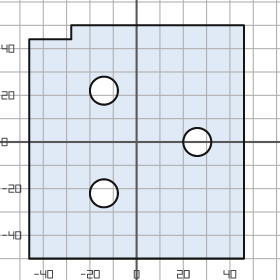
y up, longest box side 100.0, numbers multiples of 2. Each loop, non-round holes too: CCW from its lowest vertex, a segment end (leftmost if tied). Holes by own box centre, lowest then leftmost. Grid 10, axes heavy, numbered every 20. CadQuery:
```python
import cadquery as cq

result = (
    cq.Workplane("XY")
    .moveTo(-46.0, -50.0)
    .lineTo(46.0, -50.0)
    .lineTo(46.0, 50.0)
    .lineTo(-28.0, 50.0)
    .lineTo(-28.0, 44.0)
    .lineTo(-46.0, 44.0)
    .close()
    .moveTo(-14.0, -22.0)
    .circle(6.0)
    .moveTo(26.0, 0.0)
    .circle(6.0)
    .moveTo(-14.0, 22.0)
    .circle(6.0)
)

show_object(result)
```